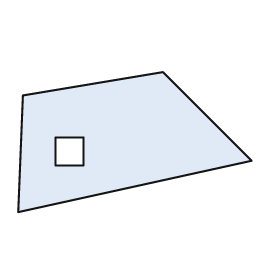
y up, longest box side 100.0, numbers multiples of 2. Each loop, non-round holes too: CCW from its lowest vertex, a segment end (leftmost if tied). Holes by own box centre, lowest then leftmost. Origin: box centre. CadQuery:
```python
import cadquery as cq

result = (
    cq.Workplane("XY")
    .moveTo(-50.0, -30.0)
    .lineTo(50.0, -8.0)
    .lineTo(12.0, 30.0)
    .lineTo(-48.0, 20.0)
    .close()
    .moveTo(-34.0, -10.0)
    .lineTo(-22.0, -10.0)
    .lineTo(-22.0, 2.0)
    .lineTo(-34.0, 2.0)
    .close()
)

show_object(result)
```